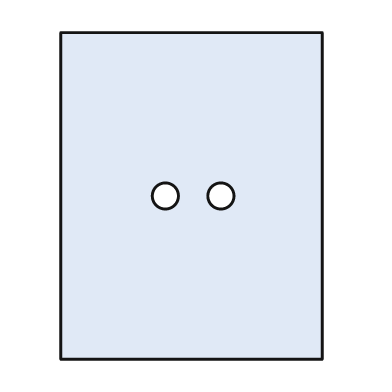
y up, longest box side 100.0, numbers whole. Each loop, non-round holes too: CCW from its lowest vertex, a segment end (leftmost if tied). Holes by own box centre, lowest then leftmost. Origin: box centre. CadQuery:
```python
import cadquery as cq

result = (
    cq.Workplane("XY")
    .moveTo(-40.0, -50.0)
    .lineTo(40.0, -50.0)
    .lineTo(40.0, 50.0)
    .lineTo(-40.0, 50.0)
    .close()
    .moveTo(-8.0, 0.0)
    .circle(4.0)
    .moveTo(9.0, 0.0)
    .circle(4.0)
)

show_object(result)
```